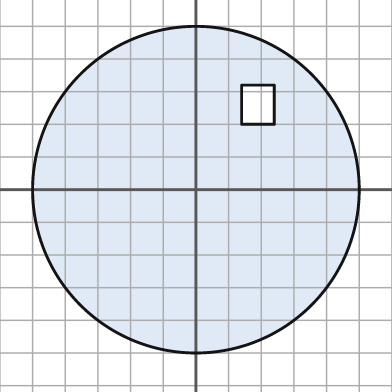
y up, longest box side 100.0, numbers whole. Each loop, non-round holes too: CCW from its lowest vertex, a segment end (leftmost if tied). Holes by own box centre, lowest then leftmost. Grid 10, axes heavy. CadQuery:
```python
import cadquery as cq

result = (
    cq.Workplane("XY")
    .moveTo(0.0, 0.0)
    .circle(50.0)
    .moveTo(14.0, 20.0)
    .lineTo(24.0, 20.0)
    .lineTo(24.0, 32.0)
    .lineTo(14.0, 32.0)
    .close()
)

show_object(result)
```